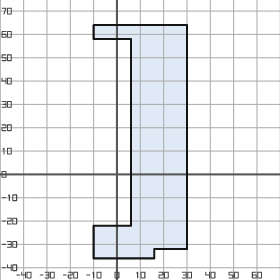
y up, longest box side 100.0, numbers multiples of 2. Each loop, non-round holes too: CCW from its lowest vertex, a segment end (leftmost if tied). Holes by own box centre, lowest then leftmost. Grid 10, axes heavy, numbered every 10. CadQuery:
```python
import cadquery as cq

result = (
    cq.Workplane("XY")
    .moveTo(-10.0, -36.0)
    .lineTo(16.0, -36.0)
    .lineTo(16.0, -32.0)
    .lineTo(30.0, -32.0)
    .lineTo(30.0, 64.0)
    .lineTo(-10.0, 64.0)
    .lineTo(-10.0, 58.0)
    .lineTo(6.0, 58.0)
    .lineTo(6.0, -22.0)
    .lineTo(-10.0, -22.0)
    .close()
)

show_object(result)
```